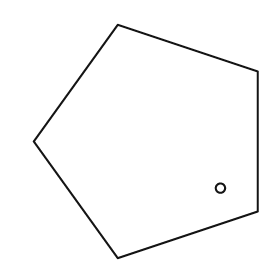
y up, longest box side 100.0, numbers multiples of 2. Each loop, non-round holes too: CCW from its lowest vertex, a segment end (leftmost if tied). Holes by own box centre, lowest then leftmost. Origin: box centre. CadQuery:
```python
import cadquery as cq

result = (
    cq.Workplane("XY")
    .moveTo(-12.0, -50.0)
    .lineTo(48.0, -30.0)
    .lineTo(48.0, 30.0)
    .lineTo(-12.0, 50.0)
    .lineTo(-48.0, 0.0)
    .close()
    .moveTo(32.0, -20.0)
    .circle(2.0)
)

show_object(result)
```